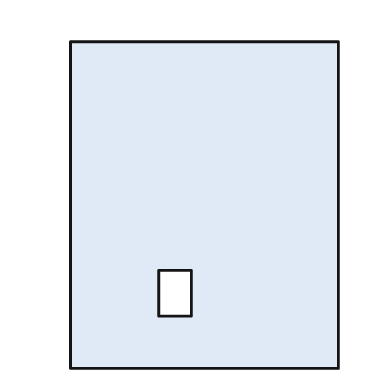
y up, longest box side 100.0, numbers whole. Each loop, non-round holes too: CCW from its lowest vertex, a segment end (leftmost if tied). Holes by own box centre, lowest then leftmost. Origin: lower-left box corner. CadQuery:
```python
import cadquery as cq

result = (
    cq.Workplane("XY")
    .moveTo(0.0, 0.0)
    .lineTo(82.0, 0.0)
    .lineTo(82.0, 100.0)
    .lineTo(0.0, 100.0)
    .close()
    .moveTo(27.0, 16.0)
    .lineTo(37.0, 16.0)
    .lineTo(37.0, 30.0)
    .lineTo(27.0, 30.0)
    .close()
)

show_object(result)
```